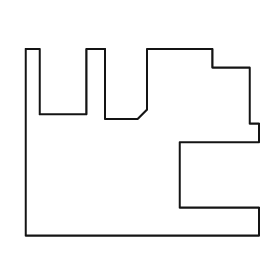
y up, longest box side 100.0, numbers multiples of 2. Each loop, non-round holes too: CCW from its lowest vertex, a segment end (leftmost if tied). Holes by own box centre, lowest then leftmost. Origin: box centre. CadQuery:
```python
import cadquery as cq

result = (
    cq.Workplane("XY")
    .moveTo(-50.0, -40.0)
    .lineTo(50.0, -40.0)
    .lineTo(50.0, -28.0)
    .lineTo(16.0, -28.0)
    .lineTo(16.0, 0.0)
    .lineTo(50.0, 0.0)
    .lineTo(50.0, 8.0)
    .lineTo(46.0, 8.0)
    .lineTo(46.0, 32.0)
    .lineTo(30.0, 32.0)
    .lineTo(30.0, 40.0)
    .lineTo(2.0, 40.0)
    .lineTo(2.0, 14.0)
    .lineTo(-2.0, 10.0)
    .lineTo(-16.0, 10.0)
    .lineTo(-16.0, 40.0)
    .lineTo(-24.0, 40.0)
    .lineTo(-24.0, 12.0)
    .lineTo(-44.0, 12.0)
    .lineTo(-44.0, 40.0)
    .lineTo(-50.0, 40.0)
    .close()
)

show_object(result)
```